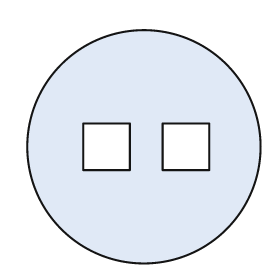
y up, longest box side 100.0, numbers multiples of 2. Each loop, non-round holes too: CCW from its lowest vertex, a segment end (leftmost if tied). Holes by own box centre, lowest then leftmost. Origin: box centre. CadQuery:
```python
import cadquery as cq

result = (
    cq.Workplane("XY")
    .moveTo(0.0, 0.0)
    .circle(50.0)
    .moveTo(-26.0, -10.0)
    .lineTo(-6.0, -10.0)
    .lineTo(-6.0, 10.0)
    .lineTo(-26.0, 10.0)
    .close()
    .moveTo(8.0, -10.0)
    .lineTo(28.0, -10.0)
    .lineTo(28.0, 10.0)
    .lineTo(8.0, 10.0)
    .close()
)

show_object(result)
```